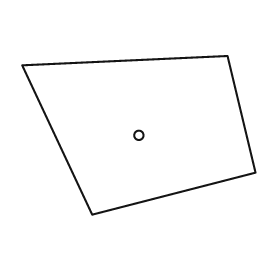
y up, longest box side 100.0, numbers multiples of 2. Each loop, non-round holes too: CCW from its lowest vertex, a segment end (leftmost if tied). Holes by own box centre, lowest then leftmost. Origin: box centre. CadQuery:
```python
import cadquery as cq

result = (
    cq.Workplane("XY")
    .moveTo(-20.0, -34.0)
    .lineTo(50.0, -16.0)
    .lineTo(38.0, 34.0)
    .lineTo(-50.0, 30.0)
    .close()
    .moveTo(0.0, 0.0)
    .circle(2.0)
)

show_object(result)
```